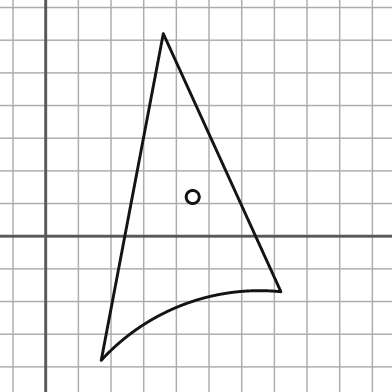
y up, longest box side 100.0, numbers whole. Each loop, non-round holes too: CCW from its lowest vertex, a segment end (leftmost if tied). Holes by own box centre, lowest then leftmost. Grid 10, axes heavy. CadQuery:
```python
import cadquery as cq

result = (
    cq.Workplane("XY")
    .moveTo(17.0, -38.0)
    .threePointArc((42.0, -21.0), (72.0, -17.0))
    .lineTo(36.0, 62.0)
    .close()
    .moveTo(45.0, 12.0)
    .circle(2.0)
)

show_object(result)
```